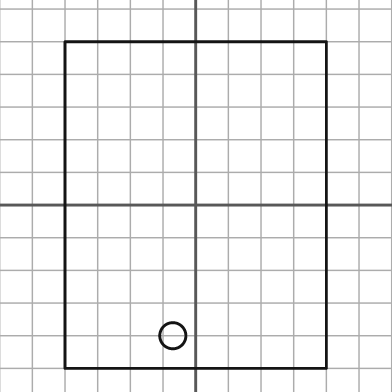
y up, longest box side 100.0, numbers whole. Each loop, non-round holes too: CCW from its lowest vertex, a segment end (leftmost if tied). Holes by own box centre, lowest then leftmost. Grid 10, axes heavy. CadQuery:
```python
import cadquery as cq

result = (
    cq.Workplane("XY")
    .moveTo(-40.0, -50.0)
    .lineTo(40.0, -50.0)
    .lineTo(40.0, 50.0)
    .lineTo(-40.0, 50.0)
    .close()
    .moveTo(-7.0, -40.0)
    .circle(4.0)
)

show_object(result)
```